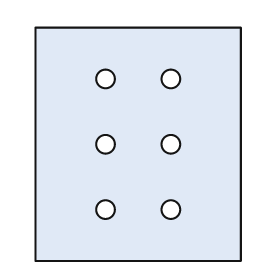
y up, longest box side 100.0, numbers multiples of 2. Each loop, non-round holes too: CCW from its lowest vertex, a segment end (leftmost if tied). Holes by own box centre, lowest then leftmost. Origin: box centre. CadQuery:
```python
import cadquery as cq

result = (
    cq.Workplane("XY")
    .moveTo(-44.0, -50.0)
    .lineTo(44.0, -50.0)
    .lineTo(44.0, 50.0)
    .lineTo(-44.0, 50.0)
    .close()
    .moveTo(-14.0, -28.0)
    .circle(4.0)
    .moveTo(14.0, -28.0)
    .circle(4.0)
    .moveTo(-14.0, 0.0)
    .circle(4.0)
    .moveTo(14.0, 0.0)
    .circle(4.0)
    .moveTo(-14.0, 28.0)
    .circle(4.0)
    .moveTo(14.0, 28.0)
    .circle(4.0)
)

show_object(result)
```